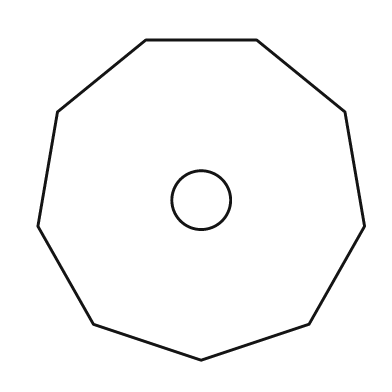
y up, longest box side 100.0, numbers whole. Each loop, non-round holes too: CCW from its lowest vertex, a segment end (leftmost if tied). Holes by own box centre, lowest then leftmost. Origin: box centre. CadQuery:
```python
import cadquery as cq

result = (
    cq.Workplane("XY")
    .moveTo(0.0, -49.0)
    .lineTo(33.0, -38.0)
    .lineTo(50.0, -8.0)
    .lineTo(44.0, 27.0)
    .lineTo(17.0, 49.0)
    .lineTo(-17.0, 49.0)
    .lineTo(-44.0, 27.0)
    .lineTo(-50.0, -8.0)
    .lineTo(-33.0, -38.0)
    .close()
    .moveTo(0.0, 0.0)
    .circle(9.0)
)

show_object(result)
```